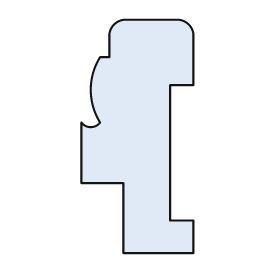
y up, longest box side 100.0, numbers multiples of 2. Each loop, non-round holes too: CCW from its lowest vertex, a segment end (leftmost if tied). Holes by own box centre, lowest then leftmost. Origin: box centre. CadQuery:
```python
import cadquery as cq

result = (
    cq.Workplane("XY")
    .moveTo(-6.0, -50.0)
    .lineTo(24.0, -50.0)
    .lineTo(24.0, -36.0)
    .lineTo(14.0, -36.0)
    .lineTo(14.0, 22.0)
    .lineTo(24.0, 22.0)
    .lineTo(24.0, 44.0)
    .threePointArc((22.0, 48.0), (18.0, 50.0))
    .lineTo(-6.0, 50.0)
    .threePointArc((-10.0, 48.0), (-12.0, 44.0))
    .lineTo(-12.0, 34.0)
    .lineTo(-16.0, 34.0)
    .threePointArc((-20.0, 20.0), (-16.0, 6.0))
    .threePointArc((-20.0, 4.0), (-24.0, 6.0))
    .lineTo(-24.0, -20.0)
    .lineTo(-6.0, -20.0)
    .close()
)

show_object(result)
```